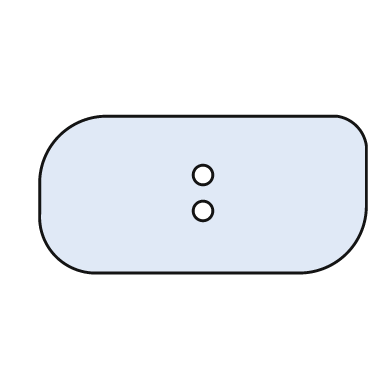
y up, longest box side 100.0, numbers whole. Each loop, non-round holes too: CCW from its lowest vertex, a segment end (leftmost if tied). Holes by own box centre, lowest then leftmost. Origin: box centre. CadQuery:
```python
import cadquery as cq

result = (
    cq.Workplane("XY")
    .moveTo(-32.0, -24.0)
    .lineTo(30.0, -24.0)
    .threePointArc((44.0, -18.0), (50.0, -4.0))
    .lineTo(50.0, 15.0)
    .threePointArc((47.0, 21.0), (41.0, 24.0))
    .lineTo(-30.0, 24.0)
    .threePointArc((-44.0, 18.0), (-50.0, 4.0))
    .lineTo(-50.0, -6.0)
    .threePointArc((-45.0, -19.0), (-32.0, -24.0))
    .close()
    .moveTo(0.0, -5.0)
    .circle(3.0)
    .moveTo(0.0, 6.0)
    .circle(3.0)
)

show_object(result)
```